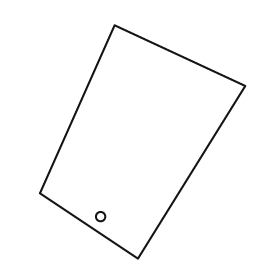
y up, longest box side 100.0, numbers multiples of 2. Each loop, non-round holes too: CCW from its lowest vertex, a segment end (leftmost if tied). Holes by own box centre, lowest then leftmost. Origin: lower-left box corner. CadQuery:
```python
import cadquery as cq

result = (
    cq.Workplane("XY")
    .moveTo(42.0, 0.0)
    .lineTo(88.0, 74.0)
    .lineTo(32.0, 100.0)
    .lineTo(0.0, 28.0)
    .close()
    .moveTo(26.0, 18.0)
    .circle(2.0)
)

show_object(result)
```